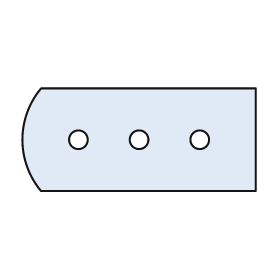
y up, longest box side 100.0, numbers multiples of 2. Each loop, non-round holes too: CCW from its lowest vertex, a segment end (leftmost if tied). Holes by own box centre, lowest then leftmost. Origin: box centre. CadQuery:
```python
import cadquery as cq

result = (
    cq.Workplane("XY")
    .moveTo(-42.0, -22.0)
    .lineTo(50.0, -22.0)
    .lineTo(50.0, 22.0)
    .lineTo(-42.0, 22.0)
    .threePointArc((-50.0, 0.0), (-42.0, -22.0))
    .close()
    .moveTo(-26.0, 0.0)
    .circle(4.0)
    .moveTo(0.0, 0.0)
    .circle(4.0)
    .moveTo(26.0, 0.0)
    .circle(4.0)
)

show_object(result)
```